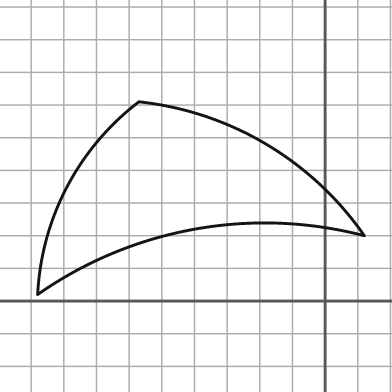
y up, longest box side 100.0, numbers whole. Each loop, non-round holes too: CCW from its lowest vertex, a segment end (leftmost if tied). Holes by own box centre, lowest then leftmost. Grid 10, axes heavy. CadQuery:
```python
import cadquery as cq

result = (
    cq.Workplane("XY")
    .moveTo(-88.0, 2.0)
    .threePointArc((-40.0, 22.0), (12.0, 20.0))
    .threePointArc((-18.0, 48.0), (-57.0, 61.0))
    .threePointArc((-79.0, 35.0), (-88.0, 2.0))
    .close()
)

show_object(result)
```